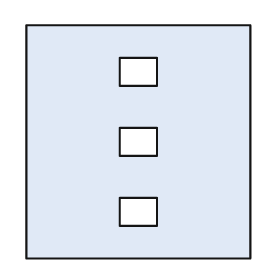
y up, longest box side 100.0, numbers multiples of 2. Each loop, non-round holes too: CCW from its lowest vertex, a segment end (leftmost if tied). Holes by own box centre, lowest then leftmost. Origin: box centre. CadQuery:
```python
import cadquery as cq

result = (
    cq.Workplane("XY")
    .moveTo(-48.0, -50.0)
    .lineTo(48.0, -50.0)
    .lineTo(48.0, 50.0)
    .lineTo(-48.0, 50.0)
    .close()
    .moveTo(-8.0, -36.0)
    .lineTo(8.0, -36.0)
    .lineTo(8.0, -24.0)
    .lineTo(-8.0, -24.0)
    .close()
    .moveTo(-8.0, -6.0)
    .lineTo(8.0, -6.0)
    .lineTo(8.0, 6.0)
    .lineTo(-8.0, 6.0)
    .close()
    .moveTo(-8.0, 24.0)
    .lineTo(8.0, 24.0)
    .lineTo(8.0, 36.0)
    .lineTo(-8.0, 36.0)
    .close()
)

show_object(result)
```